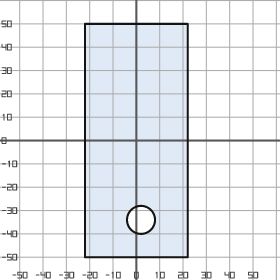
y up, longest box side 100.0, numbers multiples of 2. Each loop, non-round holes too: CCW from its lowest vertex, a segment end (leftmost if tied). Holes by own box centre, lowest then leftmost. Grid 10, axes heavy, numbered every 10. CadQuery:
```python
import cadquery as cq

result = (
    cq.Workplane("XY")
    .moveTo(-22.0, -50.0)
    .lineTo(22.0, -50.0)
    .lineTo(22.0, 50.0)
    .lineTo(-22.0, 50.0)
    .close()
    .moveTo(2.0, -34.0)
    .circle(6.0)
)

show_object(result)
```